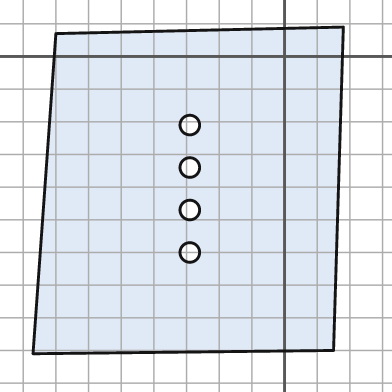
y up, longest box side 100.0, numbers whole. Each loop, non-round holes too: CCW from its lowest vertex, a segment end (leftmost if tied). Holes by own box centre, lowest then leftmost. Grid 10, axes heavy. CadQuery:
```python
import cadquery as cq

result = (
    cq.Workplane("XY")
    .moveTo(-77.0, -91.0)
    .lineTo(15.0, -90.0)
    .lineTo(18.0, 9.0)
    .lineTo(-70.0, 7.0)
    .close()
    .moveTo(-29.0, -60.0)
    .circle(3.0)
    .moveTo(-29.0, -47.0)
    .circle(3.0)
    .moveTo(-29.0, -34.0)
    .circle(3.0)
    .moveTo(-29.0, -21.0)
    .circle(3.0)
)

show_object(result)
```